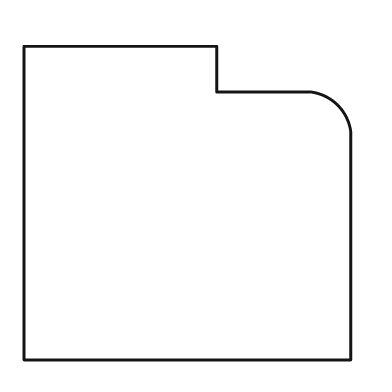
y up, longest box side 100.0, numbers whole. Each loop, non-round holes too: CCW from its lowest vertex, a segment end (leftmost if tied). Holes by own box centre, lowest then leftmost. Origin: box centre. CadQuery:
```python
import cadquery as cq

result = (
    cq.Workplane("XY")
    .moveTo(-50.0, -48.0)
    .lineTo(50.0, -48.0)
    .lineTo(50.0, 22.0)
    .threePointArc((46.0, 30.0), (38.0, 34.0))
    .lineTo(9.0, 34.0)
    .lineTo(9.0, 48.0)
    .lineTo(-50.0, 48.0)
    .close()
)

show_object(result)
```